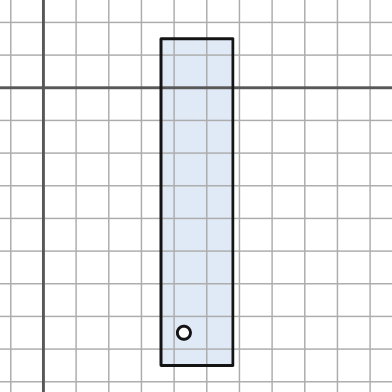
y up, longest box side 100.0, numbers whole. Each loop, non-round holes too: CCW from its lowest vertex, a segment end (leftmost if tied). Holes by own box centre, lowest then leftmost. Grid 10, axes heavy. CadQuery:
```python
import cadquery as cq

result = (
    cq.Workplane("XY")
    .moveTo(36.0, -85.0)
    .lineTo(58.0, -85.0)
    .lineTo(58.0, 15.0)
    .lineTo(36.0, 15.0)
    .close()
    .moveTo(43.0, -75.0)
    .circle(2.0)
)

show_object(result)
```